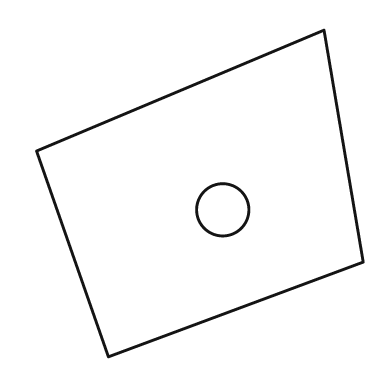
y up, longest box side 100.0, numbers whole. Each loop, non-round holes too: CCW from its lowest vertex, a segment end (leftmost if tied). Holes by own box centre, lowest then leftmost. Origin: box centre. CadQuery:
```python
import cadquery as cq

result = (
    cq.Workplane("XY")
    .moveTo(-28.0, -50.0)
    .lineTo(50.0, -21.0)
    .lineTo(38.0, 50.0)
    .lineTo(-50.0, 13.0)
    .close()
    .moveTo(7.0, -5.0)
    .circle(8.0)
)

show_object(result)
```